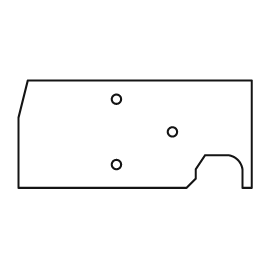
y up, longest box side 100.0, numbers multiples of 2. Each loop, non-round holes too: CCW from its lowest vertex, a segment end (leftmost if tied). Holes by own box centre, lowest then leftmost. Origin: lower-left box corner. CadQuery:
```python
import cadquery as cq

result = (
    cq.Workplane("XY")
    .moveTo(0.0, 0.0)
    .lineTo(72.0, 0.0)
    .lineTo(76.0, 4.0)
    .lineTo(76.0, 8.0)
    .lineTo(80.0, 14.0)
    .lineTo(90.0, 14.0)
    .threePointArc((94.0, 12.0), (96.0, 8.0))
    .lineTo(96.0, 0.0)
    .lineTo(100.0, 0.0)
    .lineTo(100.0, 46.0)
    .lineTo(4.0, 46.0)
    .lineTo(0.0, 30.0)
    .close()
    .moveTo(42.0, 10.0)
    .circle(2.0)
    .moveTo(66.0, 24.0)
    .circle(2.0)
    .moveTo(42.0, 38.0)
    .circle(2.0)
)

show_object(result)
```